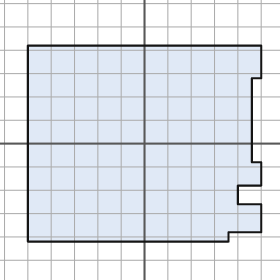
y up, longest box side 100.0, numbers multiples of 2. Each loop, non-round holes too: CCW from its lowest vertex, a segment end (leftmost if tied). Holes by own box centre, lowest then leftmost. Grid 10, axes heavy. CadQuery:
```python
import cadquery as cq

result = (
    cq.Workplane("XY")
    .moveTo(-50.0, -42.0)
    .lineTo(36.0, -42.0)
    .lineTo(36.0, -38.0)
    .lineTo(50.0, -38.0)
    .lineTo(50.0, -26.0)
    .lineTo(40.0, -26.0)
    .lineTo(40.0, -18.0)
    .lineTo(50.0, -18.0)
    .lineTo(50.0, -8.0)
    .lineTo(46.0, -8.0)
    .lineTo(46.0, 28.0)
    .lineTo(50.0, 28.0)
    .lineTo(50.0, 42.0)
    .lineTo(-50.0, 42.0)
    .close()
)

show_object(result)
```